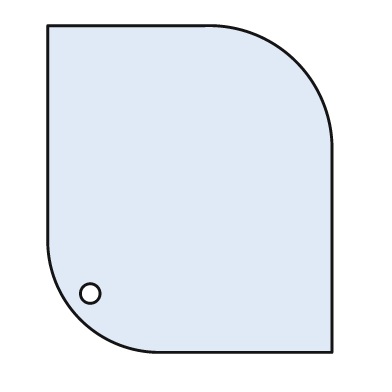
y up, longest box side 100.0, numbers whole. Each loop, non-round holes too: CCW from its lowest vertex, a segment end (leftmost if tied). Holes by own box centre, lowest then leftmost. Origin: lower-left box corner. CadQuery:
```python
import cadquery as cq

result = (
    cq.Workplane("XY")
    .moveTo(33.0, 0.0)
    .lineTo(87.0, 0.0)
    .lineTo(87.0, 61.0)
    .threePointArc((76.0, 89.0), (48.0, 100.0))
    .lineTo(0.0, 100.0)
    .lineTo(0.0, 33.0)
    .threePointArc((10.0, 10.0), (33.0, 0.0))
    .close()
    .moveTo(13.0, 18.0)
    .circle(3.0)
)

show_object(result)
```